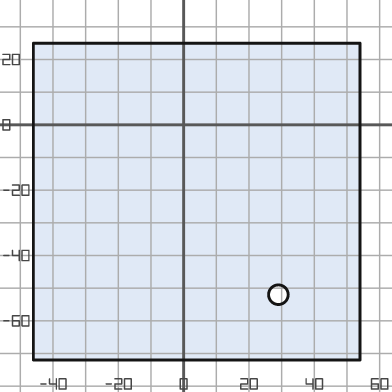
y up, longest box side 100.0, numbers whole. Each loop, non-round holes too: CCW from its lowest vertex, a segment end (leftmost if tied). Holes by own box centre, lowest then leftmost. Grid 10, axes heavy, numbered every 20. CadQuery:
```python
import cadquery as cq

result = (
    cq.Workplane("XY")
    .moveTo(-46.0, -72.0)
    .lineTo(54.0, -72.0)
    .lineTo(54.0, 25.0)
    .lineTo(-46.0, 25.0)
    .close()
    .moveTo(29.0, -52.0)
    .circle(3.0)
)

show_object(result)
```